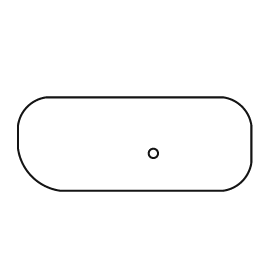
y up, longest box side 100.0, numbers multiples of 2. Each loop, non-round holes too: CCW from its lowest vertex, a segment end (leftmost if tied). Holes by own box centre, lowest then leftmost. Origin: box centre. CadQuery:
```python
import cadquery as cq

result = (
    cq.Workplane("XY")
    .moveTo(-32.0, -20.0)
    .lineTo(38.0, -20.0)
    .threePointArc((46.0, -16.0), (50.0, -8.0))
    .lineTo(50.0, 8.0)
    .threePointArc((46.0, 16.0), (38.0, 20.0))
    .lineTo(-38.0, 20.0)
    .threePointArc((-46.0, 16.0), (-50.0, 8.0))
    .lineTo(-50.0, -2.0)
    .threePointArc((-44.0, -14.0), (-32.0, -20.0))
    .close()
    .moveTo(8.0, -4.0)
    .circle(2.0)
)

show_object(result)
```